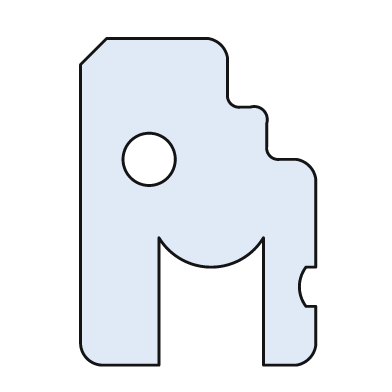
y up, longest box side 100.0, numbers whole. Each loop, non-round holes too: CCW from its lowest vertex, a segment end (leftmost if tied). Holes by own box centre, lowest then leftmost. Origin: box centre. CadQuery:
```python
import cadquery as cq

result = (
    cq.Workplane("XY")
    .moveTo(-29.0, -50.0)
    .lineTo(-12.0, -50.0)
    .lineTo(-12.0, -11.0)
    .threePointArc((4.0, -20.0), (20.0, -11.0))
    .lineTo(20.0, -50.0)
    .lineTo(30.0, -50.0)
    .threePointArc((34.0, -48.0), (36.0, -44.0))
    .lineTo(36.0, -32.0)
    .lineTo(33.0, -32.0)
    .threePointArc((31.0, -26.0), (33.0, -20.0))
    .lineTo(36.0, -20.0)
    .lineTo(36.0, 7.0)
    .threePointArc((34.0, 11.0), (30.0, 13.0))
    .lineTo(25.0, 13.0)
    .threePointArc((22.0, 14.0), (21.0, 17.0))
    .lineTo(21.0, 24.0)
    .threePointArc((20.0, 28.0), (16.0, 29.0))
    .lineTo(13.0, 29.0)
    .threePointArc((10.0, 30.0), (9.0, 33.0))
    .lineTo(9.0, 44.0)
    .threePointArc((7.0, 48.0), (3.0, 50.0))
    .lineTo(-28.0, 50.0)
    .lineTo(-36.0, 42.0)
    .lineTo(-36.0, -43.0)
    .threePointArc((-34.0, -48.0), (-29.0, -50.0))
    .close()
    .moveTo(-15.0, 13.0)
    .circle(8.0)
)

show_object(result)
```